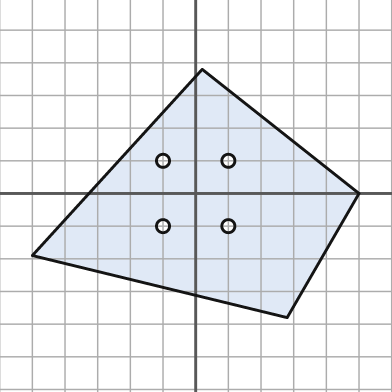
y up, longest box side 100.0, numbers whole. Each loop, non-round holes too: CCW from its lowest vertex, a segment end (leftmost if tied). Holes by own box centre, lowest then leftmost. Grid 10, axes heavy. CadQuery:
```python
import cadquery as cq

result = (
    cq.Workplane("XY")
    .moveTo(28.0, -38.0)
    .lineTo(50.0, 0.0)
    .lineTo(2.0, 38.0)
    .lineTo(-50.0, -19.0)
    .close()
    .moveTo(-10.0, -10.0)
    .circle(2.0)
    .moveTo(10.0, -10.0)
    .circle(2.0)
    .moveTo(-10.0, 10.0)
    .circle(2.0)
    .moveTo(10.0, 10.0)
    .circle(2.0)
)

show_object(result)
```